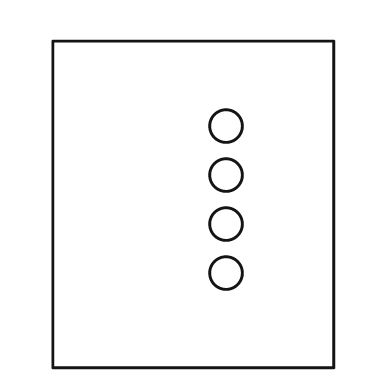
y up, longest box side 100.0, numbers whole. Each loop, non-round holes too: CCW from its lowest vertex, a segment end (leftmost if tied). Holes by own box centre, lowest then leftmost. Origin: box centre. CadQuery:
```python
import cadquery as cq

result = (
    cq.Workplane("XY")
    .moveTo(-43.0, -50.0)
    .lineTo(43.0, -50.0)
    .lineTo(43.0, 50.0)
    .lineTo(-43.0, 50.0)
    .close()
    .moveTo(10.0, -21.0)
    .circle(5.0)
    .moveTo(10.0, -6.0)
    .circle(5.0)
    .moveTo(10.0, 9.0)
    .circle(5.0)
    .moveTo(10.0, 24.0)
    .circle(5.0)
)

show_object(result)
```